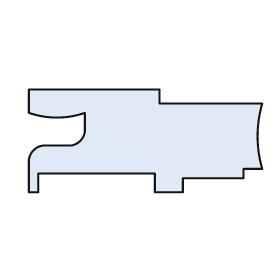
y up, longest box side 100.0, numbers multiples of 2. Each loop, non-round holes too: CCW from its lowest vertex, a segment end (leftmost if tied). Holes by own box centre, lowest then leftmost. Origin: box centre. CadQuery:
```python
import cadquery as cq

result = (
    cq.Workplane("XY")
    .moveTo(-50.0, -22.0)
    .lineTo(-46.0, -22.0)
    .lineTo(-46.0, -14.0)
    .lineTo(4.0, -14.0)
    .lineTo(4.0, -22.0)
    .lineTo(16.0, -22.0)
    .lineTo(16.0, -16.0)
    .lineTo(42.0, -16.0)
    .lineTo(42.0, -12.0)
    .lineTo(50.0, -12.0)
    .threePointArc((48.0, 2.0), (50.0, 16.0))
    .lineTo(6.0, 16.0)
    .lineTo(6.0, 22.0)
    .lineTo(-50.0, 22.0)
    .lineTo(-50.0, 12.0)
    .threePointArc((-38.0, 10.0), (-26.0, 12.0))
    .lineTo(-26.0, 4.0)
    .threePointArc((-28.0, 0.0), (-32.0, -2.0))
    .lineTo(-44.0, -2.0)
    .threePointArc((-48.0, -4.0), (-50.0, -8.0))
    .close()
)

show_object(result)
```